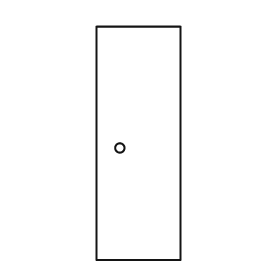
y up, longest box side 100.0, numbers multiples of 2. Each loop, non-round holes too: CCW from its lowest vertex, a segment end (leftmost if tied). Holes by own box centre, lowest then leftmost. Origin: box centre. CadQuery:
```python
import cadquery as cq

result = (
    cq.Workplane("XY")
    .moveTo(-18.0, -50.0)
    .lineTo(18.0, -50.0)
    .lineTo(18.0, 50.0)
    .lineTo(-18.0, 50.0)
    .close()
    .moveTo(-8.0, -2.0)
    .circle(2.0)
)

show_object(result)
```